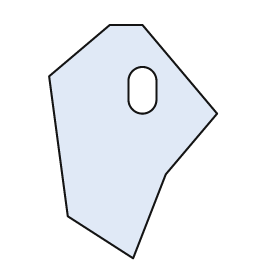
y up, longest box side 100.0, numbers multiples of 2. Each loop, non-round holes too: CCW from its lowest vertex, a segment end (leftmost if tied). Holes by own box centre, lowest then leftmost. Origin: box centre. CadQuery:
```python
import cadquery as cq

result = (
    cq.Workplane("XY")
    .moveTo(0.0, -50.0)
    .lineTo(14.0, -14.0)
    .lineTo(36.0, 12.0)
    .lineTo(4.0, 50.0)
    .lineTo(-10.0, 50.0)
    .lineTo(-36.0, 28.0)
    .lineTo(-28.0, -32.0)
    .close()
    .moveTo(-2.0, 18.0)
    .threePointArc((4.0, 12.0), (10.0, 18.0))
    .lineTo(10.0, 26.0)
    .threePointArc((4.0, 32.0), (-2.0, 26.0))
    .close()
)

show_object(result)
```